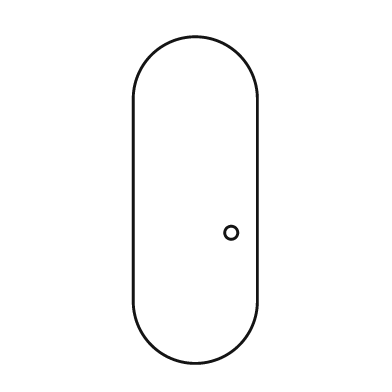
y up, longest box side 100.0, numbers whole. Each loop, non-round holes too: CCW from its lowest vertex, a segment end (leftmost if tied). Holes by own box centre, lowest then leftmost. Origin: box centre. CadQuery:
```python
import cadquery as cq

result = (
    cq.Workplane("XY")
    .moveTo(-19.0, -31.0)
    .threePointArc((0.0, -50.0), (19.0, -31.0))
    .lineTo(19.0, 31.0)
    .threePointArc((0.0, 50.0), (-19.0, 31.0))
    .close()
    .moveTo(11.0, -10.0)
    .circle(2.0)
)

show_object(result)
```